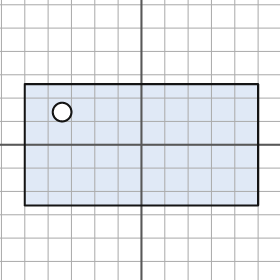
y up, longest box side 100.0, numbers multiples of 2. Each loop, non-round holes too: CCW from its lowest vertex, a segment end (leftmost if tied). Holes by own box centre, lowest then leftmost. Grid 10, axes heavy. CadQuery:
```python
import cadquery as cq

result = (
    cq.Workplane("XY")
    .moveTo(-50.0, -26.0)
    .lineTo(50.0, -26.0)
    .lineTo(50.0, 26.0)
    .lineTo(-50.0, 26.0)
    .close()
    .moveTo(-34.0, 14.0)
    .circle(4.0)
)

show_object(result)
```